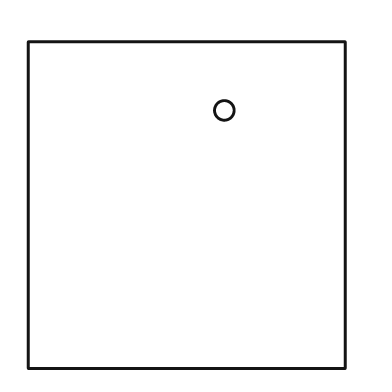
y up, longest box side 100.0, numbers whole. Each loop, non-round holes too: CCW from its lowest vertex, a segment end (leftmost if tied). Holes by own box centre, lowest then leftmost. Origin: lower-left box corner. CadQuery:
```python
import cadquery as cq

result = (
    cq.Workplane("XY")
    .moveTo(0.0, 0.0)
    .lineTo(97.0, 0.0)
    .lineTo(97.0, 100.0)
    .lineTo(0.0, 100.0)
    .close()
    .moveTo(60.0, 79.0)
    .circle(3.0)
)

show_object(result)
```